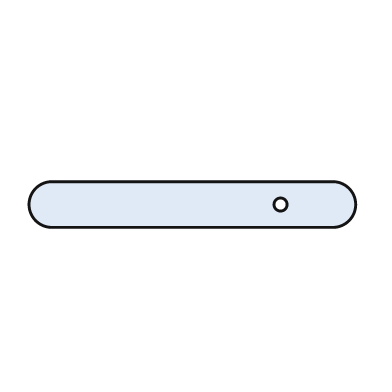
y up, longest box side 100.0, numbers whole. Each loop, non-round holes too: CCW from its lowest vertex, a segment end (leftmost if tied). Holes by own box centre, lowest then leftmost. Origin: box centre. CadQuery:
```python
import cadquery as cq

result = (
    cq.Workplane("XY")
    .moveTo(-43.0, -7.0)
    .lineTo(43.0, -7.0)
    .threePointArc((50.0, 0.0), (43.0, 7.0))
    .lineTo(-43.0, 7.0)
    .threePointArc((-50.0, 0.0), (-43.0, -7.0))
    .close()
    .moveTo(27.0, 0.0)
    .circle(2.0)
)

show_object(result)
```